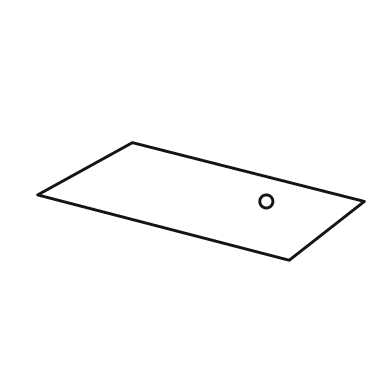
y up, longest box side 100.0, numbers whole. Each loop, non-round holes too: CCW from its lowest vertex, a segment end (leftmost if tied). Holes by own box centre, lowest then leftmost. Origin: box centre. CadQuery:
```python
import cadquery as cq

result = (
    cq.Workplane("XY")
    .moveTo(27.0, -18.0)
    .lineTo(50.0, 0.0)
    .lineTo(-21.0, 18.0)
    .lineTo(-50.0, 2.0)
    .close()
    .moveTo(20.0, 0.0)
    .circle(2.0)
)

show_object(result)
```